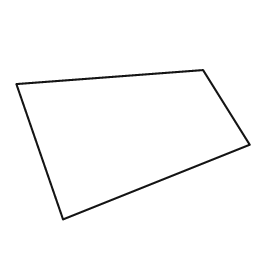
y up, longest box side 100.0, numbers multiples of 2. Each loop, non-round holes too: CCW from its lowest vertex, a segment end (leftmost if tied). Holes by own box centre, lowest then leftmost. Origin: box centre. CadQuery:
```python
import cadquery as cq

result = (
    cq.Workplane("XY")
    .moveTo(-30.0, -32.0)
    .lineTo(50.0, 0.0)
    .lineTo(30.0, 32.0)
    .lineTo(-50.0, 26.0)
    .close()
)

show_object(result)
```